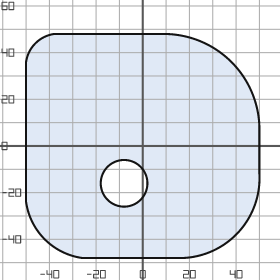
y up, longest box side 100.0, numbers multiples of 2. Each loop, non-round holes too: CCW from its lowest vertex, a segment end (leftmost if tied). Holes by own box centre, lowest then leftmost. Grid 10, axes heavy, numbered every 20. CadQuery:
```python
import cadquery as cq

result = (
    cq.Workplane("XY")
    .moveTo(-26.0, -48.0)
    .lineTo(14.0, -48.0)
    .threePointArc((40.0, -38.0), (50.0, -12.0))
    .lineTo(50.0, 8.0)
    .threePointArc((38.0, 36.0), (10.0, 48.0))
    .lineTo(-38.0, 48.0)
    .threePointArc((-46.0, 44.0), (-50.0, 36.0))
    .lineTo(-50.0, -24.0)
    .threePointArc((-42.0, -40.0), (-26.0, -48.0))
    .close()
    .moveTo(-8.0, -16.0)
    .circle(10.0)
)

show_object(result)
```